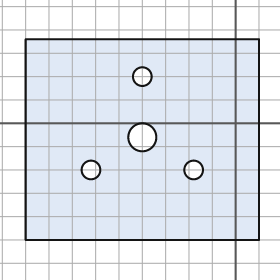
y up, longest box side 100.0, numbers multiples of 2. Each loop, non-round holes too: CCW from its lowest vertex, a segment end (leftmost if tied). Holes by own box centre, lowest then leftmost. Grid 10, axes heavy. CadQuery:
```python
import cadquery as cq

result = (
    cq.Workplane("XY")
    .moveTo(-90.0, -50.0)
    .lineTo(10.0, -50.0)
    .lineTo(10.0, 36.0)
    .lineTo(-90.0, 36.0)
    .close()
    .moveTo(-62.0, -20.0)
    .circle(4.0)
    .moveTo(-18.0, -20.0)
    .circle(4.0)
    .moveTo(-40.0, -6.0)
    .circle(6.0)
    .moveTo(-40.0, 20.0)
    .circle(4.0)
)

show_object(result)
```